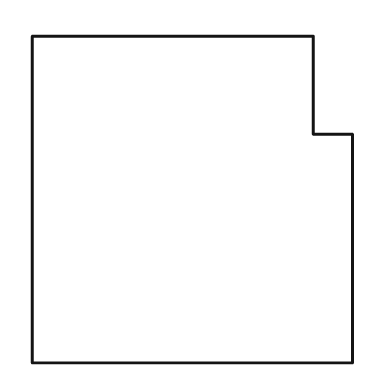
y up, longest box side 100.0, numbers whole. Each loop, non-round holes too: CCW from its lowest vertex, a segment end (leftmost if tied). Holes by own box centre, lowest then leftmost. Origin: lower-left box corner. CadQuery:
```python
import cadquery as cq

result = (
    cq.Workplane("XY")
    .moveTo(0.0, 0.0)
    .lineTo(98.0, 0.0)
    .lineTo(98.0, 70.0)
    .lineTo(86.0, 70.0)
    .lineTo(86.0, 100.0)
    .lineTo(0.0, 100.0)
    .close()
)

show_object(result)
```